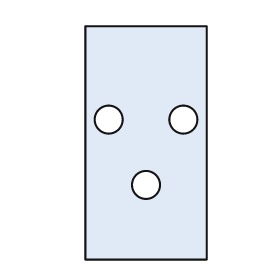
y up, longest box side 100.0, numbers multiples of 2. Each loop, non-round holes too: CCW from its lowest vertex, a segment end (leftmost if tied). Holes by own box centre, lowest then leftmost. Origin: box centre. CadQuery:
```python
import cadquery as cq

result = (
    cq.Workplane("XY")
    .moveTo(-26.0, -50.0)
    .lineTo(26.0, -50.0)
    .lineTo(26.0, 50.0)
    .lineTo(-26.0, 50.0)
    .close()
    .moveTo(0.0, -18.0)
    .circle(6.0)
    .moveTo(-16.0, 10.0)
    .circle(6.0)
    .moveTo(16.0, 10.0)
    .circle(6.0)
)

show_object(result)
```